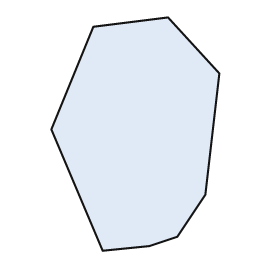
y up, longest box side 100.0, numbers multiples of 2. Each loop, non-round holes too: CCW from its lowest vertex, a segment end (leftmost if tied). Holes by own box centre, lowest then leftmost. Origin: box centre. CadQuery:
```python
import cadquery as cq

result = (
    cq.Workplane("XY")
    .moveTo(-14.0, -50.0)
    .lineTo(6.0, -48.0)
    .lineTo(18.0, -44.0)
    .lineTo(30.0, -26.0)
    .lineTo(36.0, 26.0)
    .lineTo(14.0, 50.0)
    .lineTo(-18.0, 46.0)
    .lineTo(-36.0, 2.0)
    .close()
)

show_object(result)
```